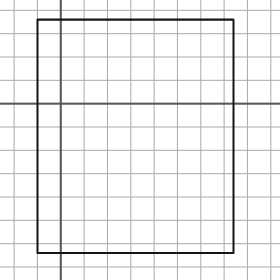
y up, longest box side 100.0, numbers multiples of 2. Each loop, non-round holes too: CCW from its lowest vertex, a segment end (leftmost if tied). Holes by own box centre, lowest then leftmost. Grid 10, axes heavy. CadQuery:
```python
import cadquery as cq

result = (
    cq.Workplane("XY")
    .moveTo(-10.0, -64.0)
    .lineTo(74.0, -64.0)
    .lineTo(74.0, 36.0)
    .lineTo(-10.0, 36.0)
    .close()
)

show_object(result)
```